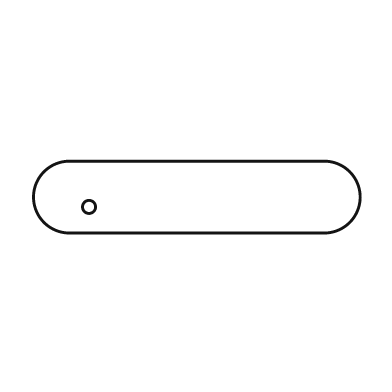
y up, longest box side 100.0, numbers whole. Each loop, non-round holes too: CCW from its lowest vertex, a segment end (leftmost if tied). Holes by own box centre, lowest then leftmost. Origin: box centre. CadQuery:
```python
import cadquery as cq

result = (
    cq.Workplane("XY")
    .moveTo(-39.0, -11.0)
    .lineTo(39.0, -11.0)
    .threePointArc((50.0, 0.0), (39.0, 11.0))
    .lineTo(-39.0, 11.0)
    .threePointArc((-50.0, 0.0), (-39.0, -11.0))
    .close()
    .moveTo(-33.0, -3.0)
    .circle(2.0)
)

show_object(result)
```